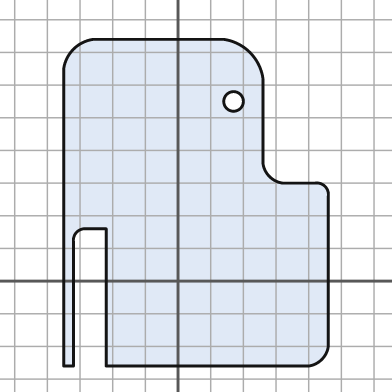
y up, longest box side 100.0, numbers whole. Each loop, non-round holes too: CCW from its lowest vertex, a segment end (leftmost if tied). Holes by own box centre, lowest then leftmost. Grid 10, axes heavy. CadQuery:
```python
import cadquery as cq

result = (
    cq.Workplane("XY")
    .moveTo(-35.0, -26.0)
    .lineTo(-32.0, -26.0)
    .lineTo(-32.0, 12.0)
    .threePointArc((-31.0, 15.0), (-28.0, 16.0))
    .lineTo(-22.0, 16.0)
    .lineTo(-22.0, -26.0)
    .lineTo(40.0, -26.0)
    .threePointArc((44.0, -24.0), (46.0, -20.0))
    .lineTo(46.0, 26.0)
    .threePointArc((45.0, 29.0), (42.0, 30.0))
    .lineTo(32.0, 30.0)
    .threePointArc((28.0, 32.0), (26.0, 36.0))
    .lineTo(26.0, 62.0)
    .threePointArc((22.0, 70.0), (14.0, 74.0))
    .lineTo(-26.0, 74.0)
    .threePointArc((-32.0, 71.0), (-35.0, 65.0))
    .close()
    .moveTo(17.0, 55.0)
    .circle(3.0)
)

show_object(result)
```